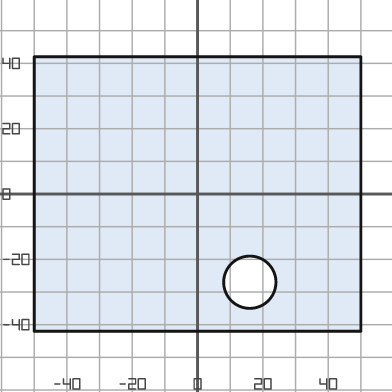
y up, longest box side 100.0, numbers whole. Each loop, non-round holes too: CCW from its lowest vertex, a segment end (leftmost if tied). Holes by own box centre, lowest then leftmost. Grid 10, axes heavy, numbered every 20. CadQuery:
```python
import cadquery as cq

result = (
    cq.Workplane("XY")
    .moveTo(-50.0, -42.0)
    .lineTo(50.0, -42.0)
    .lineTo(50.0, 42.0)
    .lineTo(-50.0, 42.0)
    .close()
    .moveTo(16.0, -27.0)
    .circle(8.0)
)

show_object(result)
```